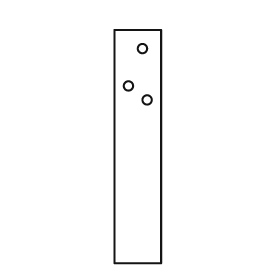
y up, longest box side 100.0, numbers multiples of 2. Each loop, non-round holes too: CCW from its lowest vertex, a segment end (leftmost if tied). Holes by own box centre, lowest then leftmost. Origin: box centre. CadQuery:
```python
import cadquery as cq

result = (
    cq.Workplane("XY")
    .moveTo(-10.0, -50.0)
    .lineTo(10.0, -50.0)
    .lineTo(10.0, 50.0)
    .lineTo(-10.0, 50.0)
    .close()
    .moveTo(4.0, 20.0)
    .circle(2.0)
    .moveTo(-4.0, 26.0)
    .circle(2.0)
    .moveTo(2.0, 42.0)
    .circle(2.0)
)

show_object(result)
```